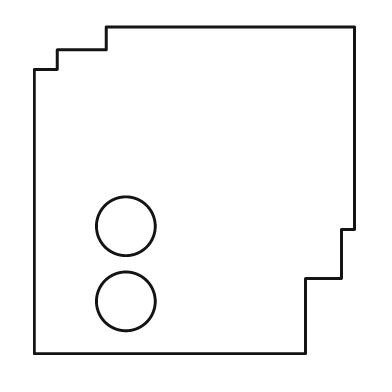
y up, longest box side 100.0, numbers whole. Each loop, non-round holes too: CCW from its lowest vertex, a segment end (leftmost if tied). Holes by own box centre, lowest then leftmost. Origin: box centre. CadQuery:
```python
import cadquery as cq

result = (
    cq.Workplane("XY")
    .moveTo(-49.0, -50.0)
    .lineTo(34.0, -50.0)
    .lineTo(34.0, -27.0)
    .lineTo(45.0, -27.0)
    .lineTo(45.0, -12.0)
    .lineTo(49.0, -12.0)
    .lineTo(49.0, 50.0)
    .lineTo(-27.0, 50.0)
    .lineTo(-27.0, 43.0)
    .lineTo(-42.0, 43.0)
    .lineTo(-42.0, 37.0)
    .lineTo(-49.0, 37.0)
    .close()
    .moveTo(-21.0, -34.0)
    .circle(9.0)
    .moveTo(-21.0, -11.0)
    .circle(9.0)
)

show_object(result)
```